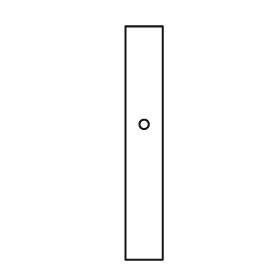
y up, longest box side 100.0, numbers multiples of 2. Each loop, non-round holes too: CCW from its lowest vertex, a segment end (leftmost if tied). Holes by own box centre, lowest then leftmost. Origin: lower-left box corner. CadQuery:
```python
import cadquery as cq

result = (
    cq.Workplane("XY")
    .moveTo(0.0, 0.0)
    .lineTo(16.0, 0.0)
    .lineTo(16.0, 100.0)
    .lineTo(0.0, 100.0)
    .close()
    .moveTo(8.0, 58.0)
    .circle(2.0)
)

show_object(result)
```